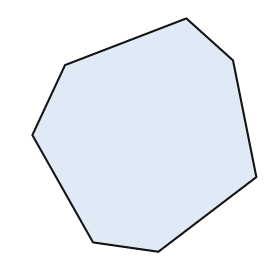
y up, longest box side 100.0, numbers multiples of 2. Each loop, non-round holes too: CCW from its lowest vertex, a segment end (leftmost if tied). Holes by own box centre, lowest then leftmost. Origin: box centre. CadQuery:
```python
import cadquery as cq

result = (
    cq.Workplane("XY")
    .moveTo(6.0, -50.0)
    .lineTo(48.0, -18.0)
    .lineTo(38.0, 32.0)
    .lineTo(18.0, 50.0)
    .lineTo(-34.0, 30.0)
    .lineTo(-48.0, 0.0)
    .lineTo(-22.0, -46.0)
    .close()
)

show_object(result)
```